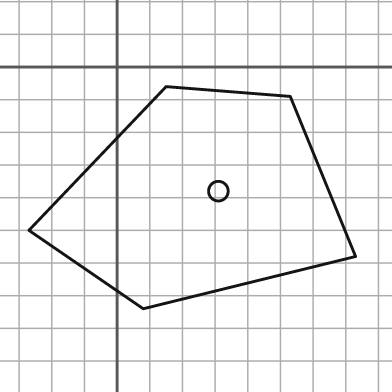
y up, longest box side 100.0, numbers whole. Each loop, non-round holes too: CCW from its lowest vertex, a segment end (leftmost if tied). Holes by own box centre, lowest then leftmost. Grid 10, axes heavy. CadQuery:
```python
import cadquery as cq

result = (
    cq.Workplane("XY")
    .moveTo(8.0, -74.0)
    .lineTo(73.0, -58.0)
    .lineTo(53.0, -9.0)
    .lineTo(15.0, -6.0)
    .lineTo(-27.0, -50.0)
    .close()
    .moveTo(31.0, -38.0)
    .circle(3.0)
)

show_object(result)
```